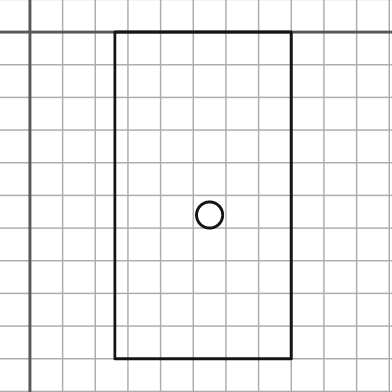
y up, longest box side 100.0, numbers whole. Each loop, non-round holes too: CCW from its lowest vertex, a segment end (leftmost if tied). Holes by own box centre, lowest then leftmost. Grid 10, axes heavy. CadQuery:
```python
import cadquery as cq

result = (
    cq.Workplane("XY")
    .moveTo(26.0, -100.0)
    .lineTo(80.0, -100.0)
    .lineTo(80.0, 0.0)
    .lineTo(26.0, 0.0)
    .close()
    .moveTo(55.0, -56.0)
    .circle(4.0)
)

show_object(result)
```